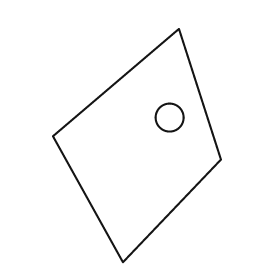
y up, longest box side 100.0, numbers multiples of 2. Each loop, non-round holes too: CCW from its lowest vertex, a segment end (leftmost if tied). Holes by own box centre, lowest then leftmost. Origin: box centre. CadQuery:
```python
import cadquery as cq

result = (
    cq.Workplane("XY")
    .moveTo(-6.0, -50.0)
    .lineTo(36.0, -6.0)
    .lineTo(18.0, 50.0)
    .lineTo(-36.0, 4.0)
    .close()
    .moveTo(14.0, 12.0)
    .circle(6.0)
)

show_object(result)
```